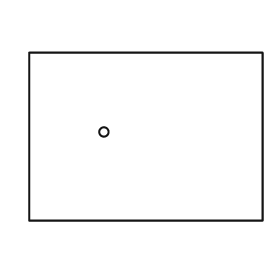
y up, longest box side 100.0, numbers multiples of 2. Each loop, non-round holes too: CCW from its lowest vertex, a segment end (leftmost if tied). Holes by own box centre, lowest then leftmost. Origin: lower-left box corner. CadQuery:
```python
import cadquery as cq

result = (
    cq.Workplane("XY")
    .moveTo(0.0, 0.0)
    .lineTo(100.0, 0.0)
    .lineTo(100.0, 72.0)
    .lineTo(0.0, 72.0)
    .close()
    .moveTo(32.0, 38.0)
    .circle(2.0)
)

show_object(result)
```